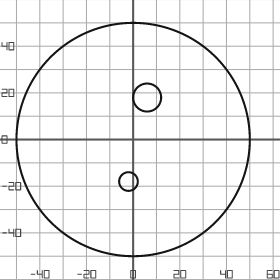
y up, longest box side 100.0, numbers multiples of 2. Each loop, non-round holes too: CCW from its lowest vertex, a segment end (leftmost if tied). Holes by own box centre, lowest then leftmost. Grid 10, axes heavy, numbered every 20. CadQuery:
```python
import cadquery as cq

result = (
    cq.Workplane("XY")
    .moveTo(0.0, 0.0)
    .circle(50.0)
    .moveTo(-2.0, -18.0)
    .circle(4.0)
    .moveTo(6.0, 18.0)
    .circle(6.0)
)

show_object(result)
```